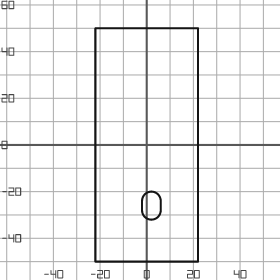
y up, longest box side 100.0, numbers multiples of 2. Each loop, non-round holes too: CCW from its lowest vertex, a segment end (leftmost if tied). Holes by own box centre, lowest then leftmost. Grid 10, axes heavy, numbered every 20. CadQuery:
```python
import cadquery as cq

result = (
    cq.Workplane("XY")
    .moveTo(-22.0, -50.0)
    .lineTo(22.0, -50.0)
    .lineTo(22.0, 50.0)
    .lineTo(-22.0, 50.0)
    .close()
    .moveTo(-2.0, -28.0)
    .threePointArc((2.0, -32.0), (6.0, -28.0))
    .lineTo(6.0, -24.0)
    .threePointArc((2.0, -20.0), (-2.0, -24.0))
    .close()
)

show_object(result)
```